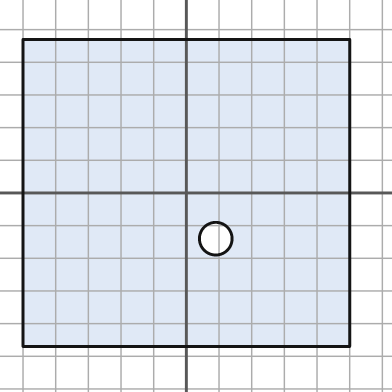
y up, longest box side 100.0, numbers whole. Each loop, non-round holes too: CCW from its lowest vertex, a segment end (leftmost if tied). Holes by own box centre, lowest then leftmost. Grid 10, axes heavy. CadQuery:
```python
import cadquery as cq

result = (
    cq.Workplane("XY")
    .moveTo(-50.0, -47.0)
    .lineTo(50.0, -47.0)
    .lineTo(50.0, 47.0)
    .lineTo(-50.0, 47.0)
    .close()
    .moveTo(9.0, -14.0)
    .circle(5.0)
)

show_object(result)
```